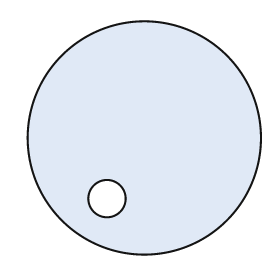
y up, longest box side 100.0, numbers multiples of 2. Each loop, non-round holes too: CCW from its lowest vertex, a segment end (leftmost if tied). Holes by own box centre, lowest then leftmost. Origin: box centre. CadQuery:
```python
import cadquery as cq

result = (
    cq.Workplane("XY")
    .moveTo(0.0, 0.0)
    .circle(50.0)
    .moveTo(-16.0, -26.0)
    .circle(8.0)
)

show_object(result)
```